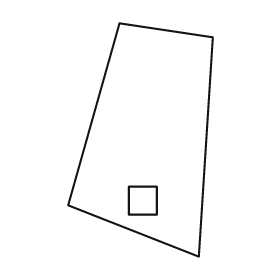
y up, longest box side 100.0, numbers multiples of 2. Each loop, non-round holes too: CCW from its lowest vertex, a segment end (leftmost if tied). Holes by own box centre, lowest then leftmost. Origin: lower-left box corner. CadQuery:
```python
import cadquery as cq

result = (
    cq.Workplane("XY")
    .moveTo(56.0, 0.0)
    .lineTo(62.0, 94.0)
    .lineTo(22.0, 100.0)
    .lineTo(0.0, 22.0)
    .close()
    .moveTo(26.0, 18.0)
    .lineTo(38.0, 18.0)
    .lineTo(38.0, 30.0)
    .lineTo(26.0, 30.0)
    .close()
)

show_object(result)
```